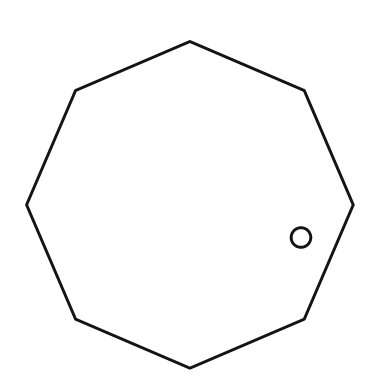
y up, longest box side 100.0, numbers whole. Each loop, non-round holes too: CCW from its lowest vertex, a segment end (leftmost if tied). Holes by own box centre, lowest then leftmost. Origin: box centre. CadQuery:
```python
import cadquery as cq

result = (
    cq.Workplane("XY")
    .moveTo(0.0, -50.0)
    .lineTo(35.0, -35.0)
    .lineTo(50.0, 0.0)
    .lineTo(35.0, 35.0)
    .lineTo(0.0, 50.0)
    .lineTo(-35.0, 35.0)
    .lineTo(-50.0, 0.0)
    .lineTo(-35.0, -35.0)
    .close()
    .moveTo(34.0, -10.0)
    .circle(3.0)
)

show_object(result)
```